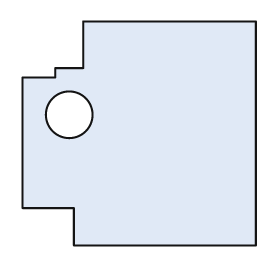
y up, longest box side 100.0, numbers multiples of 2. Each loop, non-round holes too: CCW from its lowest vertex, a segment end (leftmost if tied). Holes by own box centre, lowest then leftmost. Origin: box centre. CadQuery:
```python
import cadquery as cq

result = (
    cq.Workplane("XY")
    .moveTo(-28.0, -48.0)
    .lineTo(50.0, -48.0)
    .lineTo(50.0, 48.0)
    .lineTo(-24.0, 48.0)
    .lineTo(-24.0, 28.0)
    .lineTo(-36.0, 28.0)
    .lineTo(-36.0, 24.0)
    .lineTo(-50.0, 24.0)
    .lineTo(-50.0, -32.0)
    .lineTo(-28.0, -32.0)
    .close()
    .moveTo(-30.0, 8.0)
    .circle(10.0)
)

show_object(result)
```